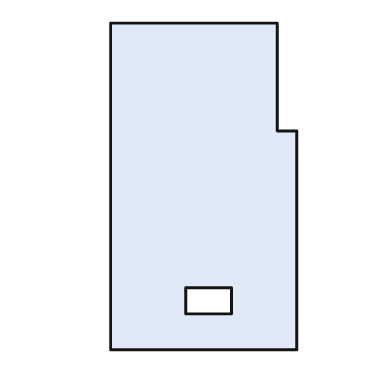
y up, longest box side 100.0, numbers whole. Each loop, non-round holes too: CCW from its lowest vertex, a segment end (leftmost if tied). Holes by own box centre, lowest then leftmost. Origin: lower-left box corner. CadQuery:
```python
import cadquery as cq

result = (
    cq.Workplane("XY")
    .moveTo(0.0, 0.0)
    .lineTo(57.0, 0.0)
    .lineTo(57.0, 67.0)
    .lineTo(51.0, 67.0)
    .lineTo(51.0, 100.0)
    .lineTo(0.0, 100.0)
    .close()
    .moveTo(23.0, 11.0)
    .lineTo(37.0, 11.0)
    .lineTo(37.0, 19.0)
    .lineTo(23.0, 19.0)
    .close()
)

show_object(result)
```